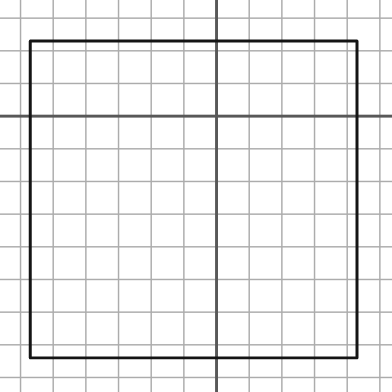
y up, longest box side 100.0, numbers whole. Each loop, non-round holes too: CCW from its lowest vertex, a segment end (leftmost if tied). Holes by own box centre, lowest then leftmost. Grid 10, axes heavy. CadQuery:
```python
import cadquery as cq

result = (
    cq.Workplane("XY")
    .moveTo(-57.0, -74.0)
    .lineTo(43.0, -74.0)
    .lineTo(43.0, 23.0)
    .lineTo(-57.0, 23.0)
    .close()
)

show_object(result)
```